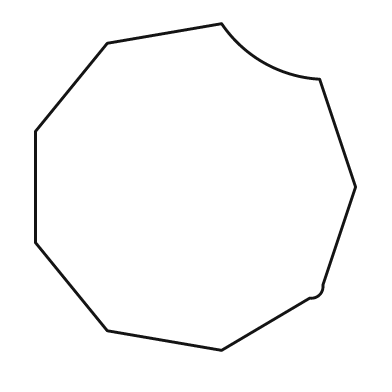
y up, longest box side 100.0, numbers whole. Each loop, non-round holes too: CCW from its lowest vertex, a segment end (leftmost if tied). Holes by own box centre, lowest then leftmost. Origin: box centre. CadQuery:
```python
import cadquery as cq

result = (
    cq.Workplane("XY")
    .moveTo(8.0, -50.0)
    .lineTo(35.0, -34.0)
    .threePointArc((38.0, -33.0), (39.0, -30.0))
    .lineTo(49.0, 0.0)
    .lineTo(38.0, 33.0)
    .threePointArc((21.0, 38.0), (8.0, 50.0))
    .lineTo(-27.0, 44.0)
    .lineTo(-49.0, 17.0)
    .lineTo(-49.0, -17.0)
    .lineTo(-27.0, -44.0)
    .close()
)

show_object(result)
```